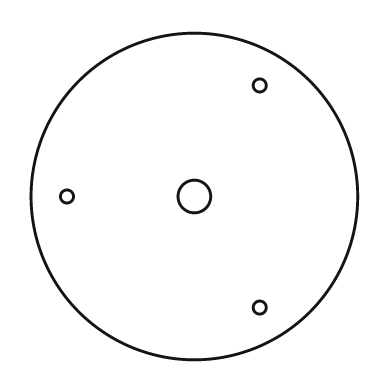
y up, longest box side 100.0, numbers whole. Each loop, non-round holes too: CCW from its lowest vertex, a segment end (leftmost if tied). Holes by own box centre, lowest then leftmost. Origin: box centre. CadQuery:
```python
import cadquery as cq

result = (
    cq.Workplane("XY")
    .moveTo(0.0, 0.0)
    .circle(50.0)
    .moveTo(20.0, -34.0)
    .circle(2.0)
    .moveTo(-39.0, 0.0)
    .circle(2.0)
    .moveTo(0.0, 0.0)
    .circle(5.0)
    .moveTo(20.0, 34.0)
    .circle(2.0)
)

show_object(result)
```